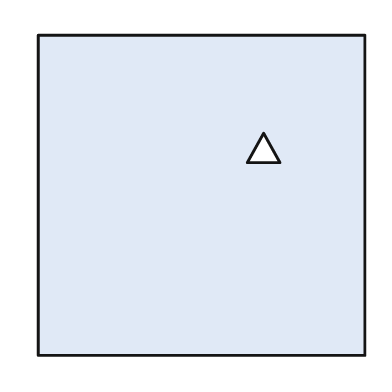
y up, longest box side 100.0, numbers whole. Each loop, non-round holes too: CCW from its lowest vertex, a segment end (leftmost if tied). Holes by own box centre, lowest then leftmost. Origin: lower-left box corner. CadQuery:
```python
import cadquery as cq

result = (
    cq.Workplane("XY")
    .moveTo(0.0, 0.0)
    .lineTo(100.0, 0.0)
    .lineTo(100.0, 98.0)
    .lineTo(0.0, 98.0)
    .close()
    .moveTo(64.0, 59.0)
    .lineTo(74.0, 59.0)
    .lineTo(69.0, 68.0)
    .close()
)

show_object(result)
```